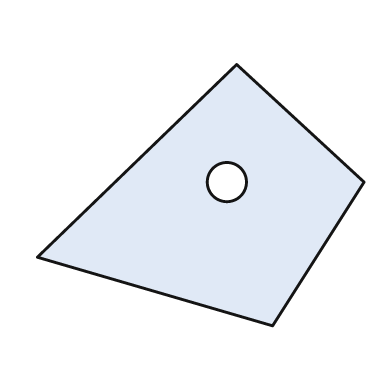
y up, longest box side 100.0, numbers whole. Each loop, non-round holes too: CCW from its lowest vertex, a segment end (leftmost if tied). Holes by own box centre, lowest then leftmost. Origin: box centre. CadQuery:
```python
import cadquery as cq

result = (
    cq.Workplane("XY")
    .moveTo(22.0, -40.0)
    .lineTo(50.0, 4.0)
    .lineTo(11.0, 40.0)
    .lineTo(-50.0, -19.0)
    .close()
    .moveTo(8.0, 4.0)
    .circle(6.0)
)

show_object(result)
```